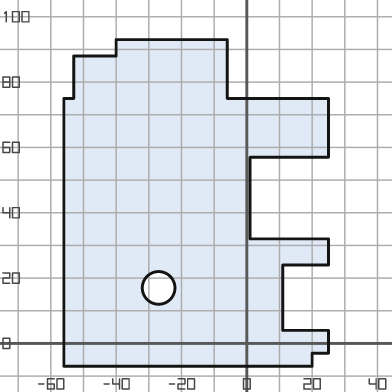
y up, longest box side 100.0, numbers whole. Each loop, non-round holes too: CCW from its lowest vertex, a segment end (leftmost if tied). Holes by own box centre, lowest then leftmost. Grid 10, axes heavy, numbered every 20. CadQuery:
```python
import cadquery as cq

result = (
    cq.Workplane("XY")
    .moveTo(-56.0, -7.0)
    .lineTo(20.0, -7.0)
    .lineTo(20.0, -3.0)
    .lineTo(25.0, -3.0)
    .lineTo(25.0, 4.0)
    .lineTo(11.0, 4.0)
    .lineTo(11.0, 24.0)
    .lineTo(25.0, 24.0)
    .lineTo(25.0, 32.0)
    .lineTo(1.0, 32.0)
    .lineTo(1.0, 57.0)
    .lineTo(25.0, 57.0)
    .lineTo(25.0, 75.0)
    .lineTo(-6.0, 75.0)
    .lineTo(-6.0, 93.0)
    .lineTo(-40.0, 93.0)
    .lineTo(-40.0, 88.0)
    .lineTo(-53.0, 88.0)
    .lineTo(-53.0, 75.0)
    .lineTo(-56.0, 75.0)
    .close()
    .moveTo(-27.0, 17.0)
    .circle(5.0)
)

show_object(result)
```